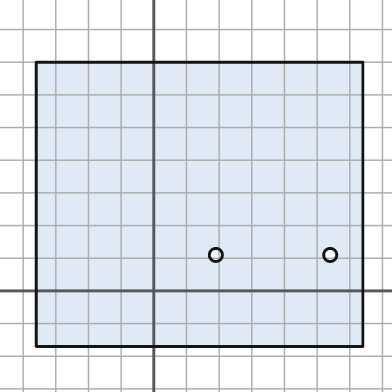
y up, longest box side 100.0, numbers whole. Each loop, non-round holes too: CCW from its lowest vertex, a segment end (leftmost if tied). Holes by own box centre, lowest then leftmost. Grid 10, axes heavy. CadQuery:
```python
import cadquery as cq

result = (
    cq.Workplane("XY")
    .moveTo(-36.0, -17.0)
    .lineTo(64.0, -17.0)
    .lineTo(64.0, 70.0)
    .lineTo(-36.0, 70.0)
    .close()
    .moveTo(19.0, 11.0)
    .circle(2.0)
    .moveTo(54.0, 11.0)
    .circle(2.0)
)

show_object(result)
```